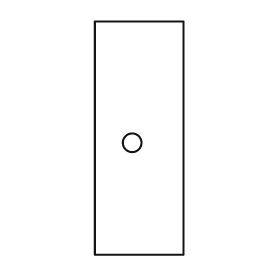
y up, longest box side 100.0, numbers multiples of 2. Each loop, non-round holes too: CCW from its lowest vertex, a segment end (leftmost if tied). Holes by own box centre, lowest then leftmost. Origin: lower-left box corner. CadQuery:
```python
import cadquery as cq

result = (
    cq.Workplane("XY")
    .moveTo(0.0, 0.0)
    .lineTo(38.0, 0.0)
    .lineTo(38.0, 100.0)
    .lineTo(0.0, 100.0)
    .close()
    .moveTo(16.0, 48.0)
    .circle(4.0)
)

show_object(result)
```